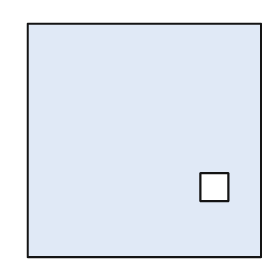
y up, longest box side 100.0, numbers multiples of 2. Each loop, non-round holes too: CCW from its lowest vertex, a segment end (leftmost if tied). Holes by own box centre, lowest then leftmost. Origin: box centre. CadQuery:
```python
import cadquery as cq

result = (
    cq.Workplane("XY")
    .moveTo(-50.0, -50.0)
    .lineTo(50.0, -50.0)
    .lineTo(50.0, 50.0)
    .lineTo(-50.0, 50.0)
    .close()
    .moveTo(24.0, -26.0)
    .lineTo(36.0, -26.0)
    .lineTo(36.0, -14.0)
    .lineTo(24.0, -14.0)
    .close()
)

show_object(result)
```